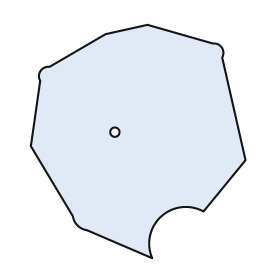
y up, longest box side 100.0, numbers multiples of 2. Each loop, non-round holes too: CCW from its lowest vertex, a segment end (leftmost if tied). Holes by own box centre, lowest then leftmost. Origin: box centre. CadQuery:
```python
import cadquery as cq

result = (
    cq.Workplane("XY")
    .moveTo(6.0, -50.0)
    .threePointArc((10.0, -32.0), (28.0, -30.0))
    .lineTo(46.0, -8.0)
    .lineTo(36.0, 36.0)
    .threePointArc((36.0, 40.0), (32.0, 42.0))
    .lineTo(4.0, 50.0)
    .lineTo(-14.0, 46.0)
    .lineTo(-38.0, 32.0)
    .threePointArc((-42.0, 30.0), (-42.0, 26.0))
    .lineTo(-46.0, -2.0)
    .lineTo(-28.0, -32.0)
    .threePointArc((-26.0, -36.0), (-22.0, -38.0))
    .close()
    .moveTo(-10.0, 4.0)
    .circle(2.0)
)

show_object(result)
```